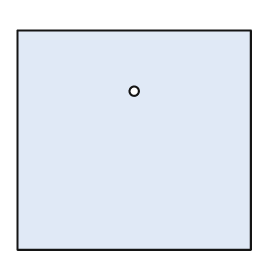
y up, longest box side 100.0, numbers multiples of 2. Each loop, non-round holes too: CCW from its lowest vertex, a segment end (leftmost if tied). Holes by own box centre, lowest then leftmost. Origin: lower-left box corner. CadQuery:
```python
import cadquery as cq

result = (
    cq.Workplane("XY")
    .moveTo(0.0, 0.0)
    .lineTo(100.0, 0.0)
    .lineTo(100.0, 94.0)
    .lineTo(0.0, 94.0)
    .close()
    .moveTo(50.0, 68.0)
    .circle(2.0)
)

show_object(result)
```